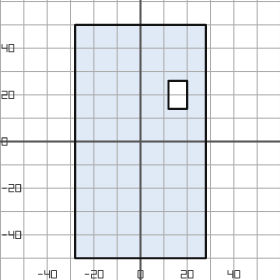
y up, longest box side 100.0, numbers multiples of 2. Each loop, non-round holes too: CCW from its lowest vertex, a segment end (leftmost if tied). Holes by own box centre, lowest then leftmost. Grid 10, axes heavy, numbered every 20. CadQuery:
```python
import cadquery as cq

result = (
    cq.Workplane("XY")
    .moveTo(-28.0, -50.0)
    .lineTo(28.0, -50.0)
    .lineTo(28.0, 50.0)
    .lineTo(-28.0, 50.0)
    .close()
    .moveTo(12.0, 14.0)
    .lineTo(20.0, 14.0)
    .lineTo(20.0, 26.0)
    .lineTo(12.0, 26.0)
    .close()
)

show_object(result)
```